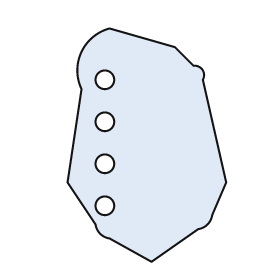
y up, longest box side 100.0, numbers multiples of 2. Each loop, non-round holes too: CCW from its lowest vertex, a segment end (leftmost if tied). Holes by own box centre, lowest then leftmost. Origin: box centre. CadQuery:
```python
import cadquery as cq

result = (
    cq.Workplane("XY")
    .moveTo(2.0, -50.0)
    .lineTo(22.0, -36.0)
    .threePointArc((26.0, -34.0), (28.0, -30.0))
    .lineTo(34.0, -16.0)
    .lineTo(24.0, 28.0)
    .threePointArc((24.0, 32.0), (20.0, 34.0))
    .lineTo(12.0, 42.0)
    .lineTo(-16.0, 50.0)
    .threePointArc((-28.0, 40.0), (-28.0, 24.0))
    .lineTo(-34.0, -16.0)
    .lineTo(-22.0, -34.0)
    .threePointArc((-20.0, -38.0), (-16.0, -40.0))
    .close()
    .moveTo(-18.0, -26.0)
    .circle(4.0)
    .moveTo(-18.0, -8.0)
    .circle(4.0)
    .moveTo(-18.0, 10.0)
    .circle(4.0)
    .moveTo(-18.0, 28.0)
    .circle(4.0)
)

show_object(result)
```